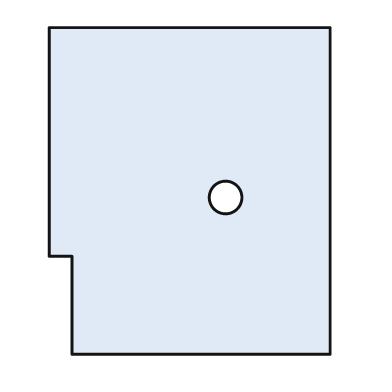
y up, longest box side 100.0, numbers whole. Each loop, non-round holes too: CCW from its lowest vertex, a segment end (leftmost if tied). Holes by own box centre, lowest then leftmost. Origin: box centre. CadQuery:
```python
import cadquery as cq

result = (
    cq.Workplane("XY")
    .moveTo(-36.0, -50.0)
    .lineTo(43.0, -50.0)
    .lineTo(43.0, 50.0)
    .lineTo(-43.0, 50.0)
    .lineTo(-43.0, -20.0)
    .lineTo(-36.0, -20.0)
    .close()
    .moveTo(11.0, -2.0)
    .circle(5.0)
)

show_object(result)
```